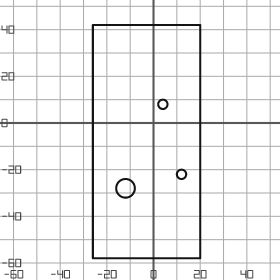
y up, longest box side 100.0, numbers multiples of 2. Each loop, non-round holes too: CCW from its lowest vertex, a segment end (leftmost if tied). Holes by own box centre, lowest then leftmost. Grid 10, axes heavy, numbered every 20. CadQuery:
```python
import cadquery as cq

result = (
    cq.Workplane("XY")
    .moveTo(-26.0, -58.0)
    .lineTo(20.0, -58.0)
    .lineTo(20.0, 42.0)
    .lineTo(-26.0, 42.0)
    .close()
    .moveTo(-12.0, -28.0)
    .circle(4.0)
    .moveTo(12.0, -22.0)
    .circle(2.0)
    .moveTo(4.0, 8.0)
    .circle(2.0)
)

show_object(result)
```